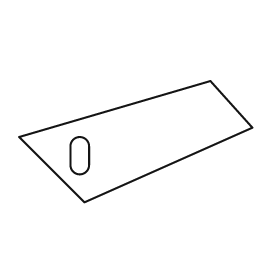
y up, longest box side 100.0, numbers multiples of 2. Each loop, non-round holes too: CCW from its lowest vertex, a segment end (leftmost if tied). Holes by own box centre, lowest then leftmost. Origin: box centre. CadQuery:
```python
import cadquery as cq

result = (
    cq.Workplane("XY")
    .moveTo(-22.0, -26.0)
    .lineTo(50.0, 6.0)
    .lineTo(32.0, 26.0)
    .lineTo(-50.0, 2.0)
    .close()
    .moveTo(-28.0, -10.0)
    .threePointArc((-24.0, -14.0), (-20.0, -10.0))
    .lineTo(-20.0, -2.0)
    .threePointArc((-24.0, 2.0), (-28.0, -2.0))
    .close()
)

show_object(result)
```